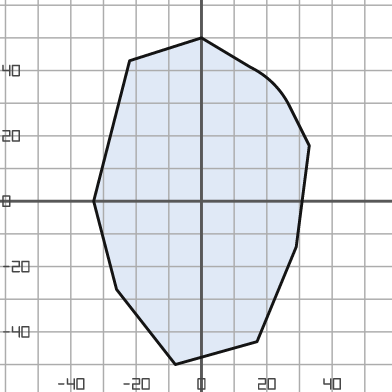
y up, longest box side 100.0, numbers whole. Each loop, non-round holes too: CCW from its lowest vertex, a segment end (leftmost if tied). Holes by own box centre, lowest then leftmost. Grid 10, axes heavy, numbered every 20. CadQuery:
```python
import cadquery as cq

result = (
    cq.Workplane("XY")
    .moveTo(-8.0, -50.0)
    .lineTo(17.0, -43.0)
    .lineTo(29.0, -14.0)
    .lineTo(33.0, 17.0)
    .lineTo(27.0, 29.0)
    .threePointArc((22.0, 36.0), (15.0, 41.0))
    .lineTo(0.0, 50.0)
    .lineTo(-22.0, 43.0)
    .lineTo(-33.0, 0.0)
    .lineTo(-26.0, -27.0)
    .close()
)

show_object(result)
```